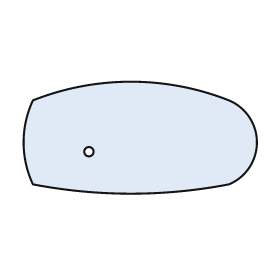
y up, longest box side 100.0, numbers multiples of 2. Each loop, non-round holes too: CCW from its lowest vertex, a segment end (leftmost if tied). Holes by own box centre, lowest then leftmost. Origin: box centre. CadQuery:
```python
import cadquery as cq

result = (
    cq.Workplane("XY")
    .moveTo(-46.0, -20.0)
    .threePointArc((-4.0, -24.0), (38.0, -20.0))
    .threePointArc((50.0, -2.0), (38.0, 16.0))
    .threePointArc((-4.0, 24.0), (-46.0, 16.0))
    .threePointArc((-50.0, -2.0), (-46.0, -20.0))
    .close()
    .moveTo(-22.0, -6.0)
    .circle(2.0)
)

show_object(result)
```